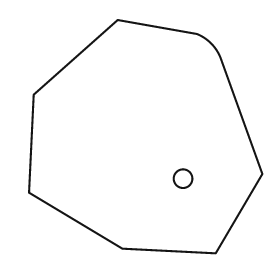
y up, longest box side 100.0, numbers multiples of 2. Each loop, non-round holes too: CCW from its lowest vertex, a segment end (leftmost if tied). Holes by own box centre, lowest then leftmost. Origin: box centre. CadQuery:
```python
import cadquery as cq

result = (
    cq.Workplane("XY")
    .moveTo(30.0, -50.0)
    .lineTo(50.0, -16.0)
    .lineTo(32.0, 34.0)
    .threePointArc((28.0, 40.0), (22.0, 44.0))
    .lineTo(-12.0, 50.0)
    .lineTo(-48.0, 18.0)
    .lineTo(-50.0, -24.0)
    .lineTo(-10.0, -48.0)
    .close()
    .moveTo(16.0, -18.0)
    .circle(4.0)
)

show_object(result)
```